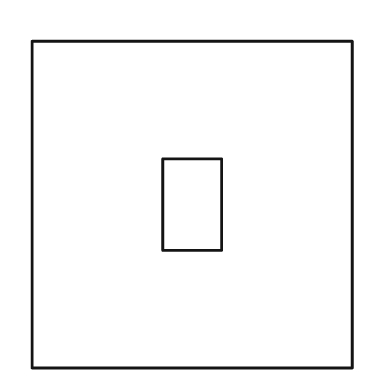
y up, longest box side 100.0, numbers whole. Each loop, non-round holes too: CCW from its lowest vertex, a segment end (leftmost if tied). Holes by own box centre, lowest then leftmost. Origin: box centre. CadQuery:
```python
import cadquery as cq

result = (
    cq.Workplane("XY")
    .moveTo(-49.0, -50.0)
    .lineTo(49.0, -50.0)
    .lineTo(49.0, 50.0)
    .lineTo(-49.0, 50.0)
    .close()
    .moveTo(-9.0, -14.0)
    .lineTo(9.0, -14.0)
    .lineTo(9.0, 14.0)
    .lineTo(-9.0, 14.0)
    .close()
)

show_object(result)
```